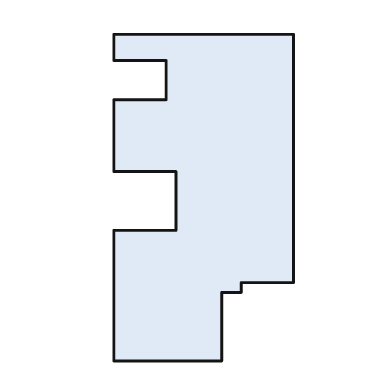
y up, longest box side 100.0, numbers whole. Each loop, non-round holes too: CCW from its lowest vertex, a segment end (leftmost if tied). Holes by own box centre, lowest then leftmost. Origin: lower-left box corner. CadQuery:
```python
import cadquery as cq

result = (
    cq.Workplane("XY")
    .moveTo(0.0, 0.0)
    .lineTo(33.0, 0.0)
    .lineTo(33.0, 21.0)
    .lineTo(39.0, 21.0)
    .lineTo(39.0, 24.0)
    .lineTo(55.0, 24.0)
    .lineTo(55.0, 100.0)
    .lineTo(0.0, 100.0)
    .lineTo(0.0, 92.0)
    .lineTo(16.0, 92.0)
    .lineTo(16.0, 80.0)
    .lineTo(0.0, 80.0)
    .lineTo(0.0, 58.0)
    .lineTo(19.0, 58.0)
    .lineTo(19.0, 40.0)
    .lineTo(0.0, 40.0)
    .close()
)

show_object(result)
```